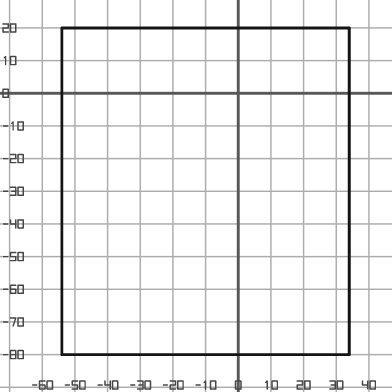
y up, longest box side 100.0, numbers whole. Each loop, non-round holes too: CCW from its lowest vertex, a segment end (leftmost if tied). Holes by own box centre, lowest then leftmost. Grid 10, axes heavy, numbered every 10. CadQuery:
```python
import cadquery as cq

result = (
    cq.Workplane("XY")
    .moveTo(-54.0, -80.0)
    .lineTo(34.0, -80.0)
    .lineTo(34.0, 20.0)
    .lineTo(-54.0, 20.0)
    .close()
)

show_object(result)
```